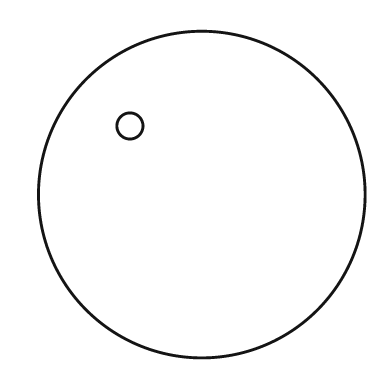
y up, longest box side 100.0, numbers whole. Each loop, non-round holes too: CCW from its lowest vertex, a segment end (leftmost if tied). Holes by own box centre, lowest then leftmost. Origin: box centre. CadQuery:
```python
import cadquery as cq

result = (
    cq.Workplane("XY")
    .moveTo(0.0, 0.0)
    .circle(50.0)
    .moveTo(-22.0, 21.0)
    .circle(4.0)
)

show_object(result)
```